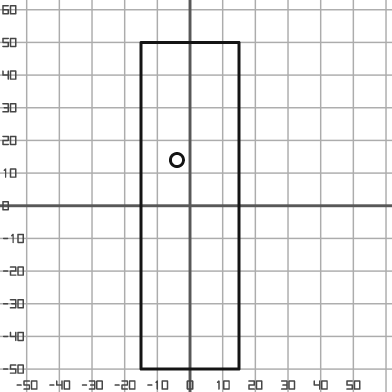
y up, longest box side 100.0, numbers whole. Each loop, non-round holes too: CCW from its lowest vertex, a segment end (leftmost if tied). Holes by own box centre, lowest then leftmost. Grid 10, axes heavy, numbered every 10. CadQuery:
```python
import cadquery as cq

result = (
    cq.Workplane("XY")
    .moveTo(-15.0, -50.0)
    .lineTo(15.0, -50.0)
    .lineTo(15.0, 50.0)
    .lineTo(-15.0, 50.0)
    .close()
    .moveTo(-4.0, 14.0)
    .circle(2.0)
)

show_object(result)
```